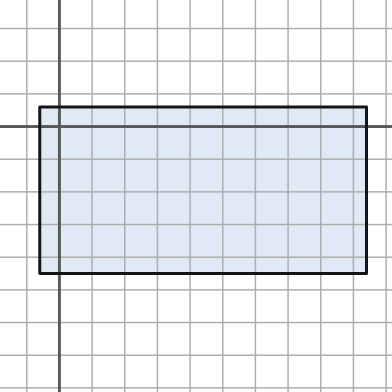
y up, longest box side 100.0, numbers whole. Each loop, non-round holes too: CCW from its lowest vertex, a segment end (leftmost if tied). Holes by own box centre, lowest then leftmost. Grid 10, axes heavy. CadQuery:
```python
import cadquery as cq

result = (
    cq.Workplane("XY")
    .moveTo(-6.0, -45.0)
    .lineTo(94.0, -45.0)
    .lineTo(94.0, 6.0)
    .lineTo(-6.0, 6.0)
    .close()
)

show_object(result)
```